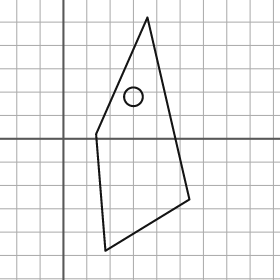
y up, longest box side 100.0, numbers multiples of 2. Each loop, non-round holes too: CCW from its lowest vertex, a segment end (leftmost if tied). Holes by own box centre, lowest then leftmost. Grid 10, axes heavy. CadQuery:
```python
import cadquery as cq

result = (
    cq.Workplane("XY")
    .moveTo(18.0, -48.0)
    .lineTo(54.0, -26.0)
    .lineTo(36.0, 52.0)
    .lineTo(14.0, 2.0)
    .close()
    .moveTo(30.0, 18.0)
    .circle(4.0)
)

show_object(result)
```